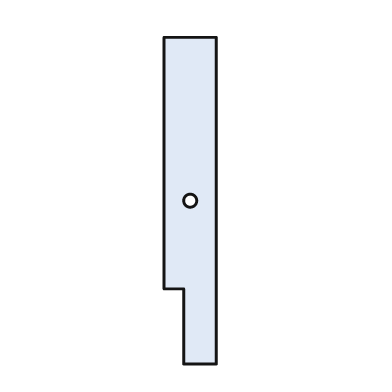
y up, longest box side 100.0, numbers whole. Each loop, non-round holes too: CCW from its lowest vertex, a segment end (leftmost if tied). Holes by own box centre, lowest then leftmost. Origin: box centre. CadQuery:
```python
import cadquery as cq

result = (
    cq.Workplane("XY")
    .moveTo(-2.0, -50.0)
    .lineTo(8.0, -50.0)
    .lineTo(8.0, 50.0)
    .lineTo(-8.0, 50.0)
    .lineTo(-8.0, -27.0)
    .lineTo(-2.0, -27.0)
    .close()
    .moveTo(0.0, 0.0)
    .circle(2.0)
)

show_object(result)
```